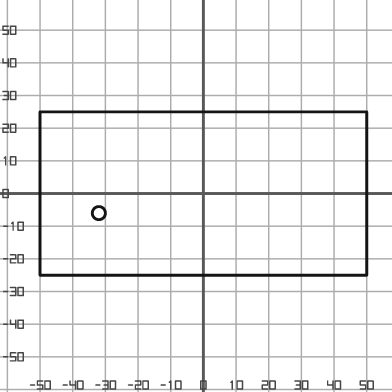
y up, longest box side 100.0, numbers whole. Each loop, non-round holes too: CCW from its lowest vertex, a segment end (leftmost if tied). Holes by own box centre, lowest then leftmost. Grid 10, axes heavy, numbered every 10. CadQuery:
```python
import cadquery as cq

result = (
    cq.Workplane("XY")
    .moveTo(-50.0, -25.0)
    .lineTo(50.0, -25.0)
    .lineTo(50.0, 25.0)
    .lineTo(-50.0, 25.0)
    .close()
    .moveTo(-32.0, -6.0)
    .circle(2.0)
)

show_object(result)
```